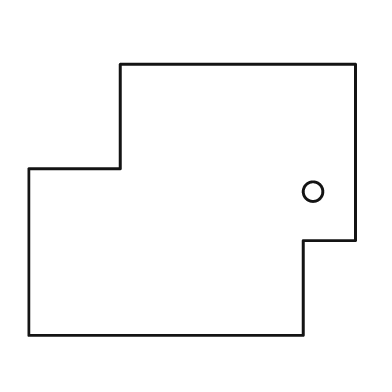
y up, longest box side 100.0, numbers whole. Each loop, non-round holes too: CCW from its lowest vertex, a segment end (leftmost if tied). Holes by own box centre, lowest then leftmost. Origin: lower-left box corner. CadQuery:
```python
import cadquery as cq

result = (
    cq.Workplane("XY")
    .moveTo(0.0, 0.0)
    .lineTo(84.0, 0.0)
    .lineTo(84.0, 29.0)
    .lineTo(100.0, 29.0)
    .lineTo(100.0, 83.0)
    .lineTo(28.0, 83.0)
    .lineTo(28.0, 51.0)
    .lineTo(0.0, 51.0)
    .close()
    .moveTo(87.0, 44.0)
    .circle(3.0)
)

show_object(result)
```